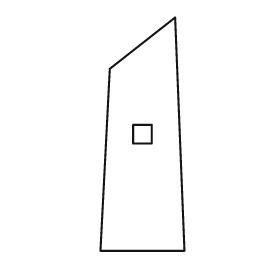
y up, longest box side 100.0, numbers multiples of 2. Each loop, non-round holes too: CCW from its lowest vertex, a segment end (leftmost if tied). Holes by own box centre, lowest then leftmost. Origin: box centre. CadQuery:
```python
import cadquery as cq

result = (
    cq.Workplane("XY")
    .moveTo(-18.0, -50.0)
    .lineTo(18.0, -50.0)
    .lineTo(14.0, 50.0)
    .lineTo(-14.0, 28.0)
    .close()
    .moveTo(-4.0, -4.0)
    .lineTo(4.0, -4.0)
    .lineTo(4.0, 4.0)
    .lineTo(-4.0, 4.0)
    .close()
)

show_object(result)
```